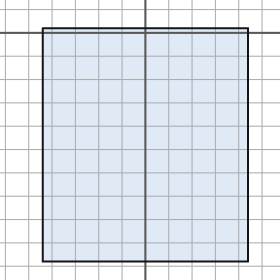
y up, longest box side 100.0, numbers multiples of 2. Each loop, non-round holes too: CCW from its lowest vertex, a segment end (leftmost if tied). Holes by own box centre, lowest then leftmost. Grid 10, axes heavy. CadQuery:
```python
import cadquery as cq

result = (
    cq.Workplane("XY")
    .moveTo(-44.0, -98.0)
    .lineTo(44.0, -98.0)
    .lineTo(44.0, 2.0)
    .lineTo(-44.0, 2.0)
    .close()
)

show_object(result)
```